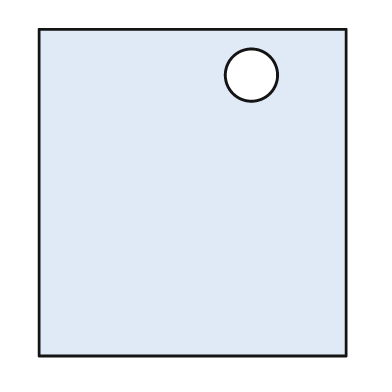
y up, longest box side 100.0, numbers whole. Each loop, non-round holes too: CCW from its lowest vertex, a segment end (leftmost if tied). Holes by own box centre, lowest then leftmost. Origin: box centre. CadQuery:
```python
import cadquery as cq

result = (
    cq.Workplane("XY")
    .moveTo(-47.0, -50.0)
    .lineTo(47.0, -50.0)
    .lineTo(47.0, 50.0)
    .lineTo(-47.0, 50.0)
    .close()
    .moveTo(18.0, 36.0)
    .circle(8.0)
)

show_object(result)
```